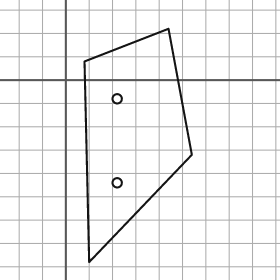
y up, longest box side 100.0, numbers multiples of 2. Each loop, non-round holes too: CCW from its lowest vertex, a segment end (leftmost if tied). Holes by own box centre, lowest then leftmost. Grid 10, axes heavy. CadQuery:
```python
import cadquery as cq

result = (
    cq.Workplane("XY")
    .moveTo(10.0, -78.0)
    .lineTo(54.0, -32.0)
    .lineTo(44.0, 22.0)
    .lineTo(8.0, 8.0)
    .close()
    .moveTo(22.0, -44.0)
    .circle(2.0)
    .moveTo(22.0, -8.0)
    .circle(2.0)
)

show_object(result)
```